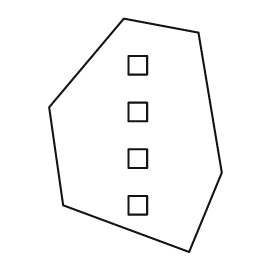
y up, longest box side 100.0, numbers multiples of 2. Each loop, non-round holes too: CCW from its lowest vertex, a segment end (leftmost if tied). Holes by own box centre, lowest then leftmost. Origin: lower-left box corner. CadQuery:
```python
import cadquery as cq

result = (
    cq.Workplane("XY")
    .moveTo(60.0, 0.0)
    .lineTo(74.0, 34.0)
    .lineTo(64.0, 94.0)
    .lineTo(32.0, 100.0)
    .lineTo(0.0, 62.0)
    .lineTo(6.0, 20.0)
    .close()
    .moveTo(34.0, 16.0)
    .lineTo(42.0, 16.0)
    .lineTo(42.0, 24.0)
    .lineTo(34.0, 24.0)
    .close()
    .moveTo(34.0, 36.0)
    .lineTo(42.0, 36.0)
    .lineTo(42.0, 44.0)
    .lineTo(34.0, 44.0)
    .close()
    .moveTo(34.0, 56.0)
    .lineTo(42.0, 56.0)
    .lineTo(42.0, 64.0)
    .lineTo(34.0, 64.0)
    .close()
    .moveTo(34.0, 76.0)
    .lineTo(42.0, 76.0)
    .lineTo(42.0, 84.0)
    .lineTo(34.0, 84.0)
    .close()
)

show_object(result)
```